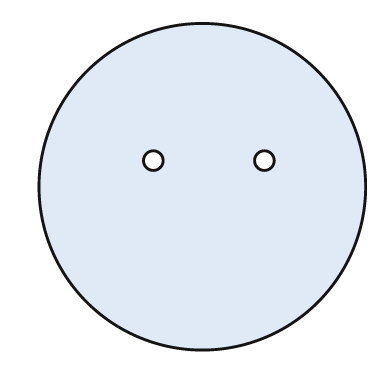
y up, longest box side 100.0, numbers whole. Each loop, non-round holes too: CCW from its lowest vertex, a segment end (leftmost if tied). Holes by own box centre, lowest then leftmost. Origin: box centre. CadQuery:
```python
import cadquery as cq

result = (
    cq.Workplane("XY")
    .moveTo(0.0, 0.0)
    .circle(50.0)
    .moveTo(-15.0, 8.0)
    .circle(3.0)
    .moveTo(19.0, 8.0)
    .circle(3.0)
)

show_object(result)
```